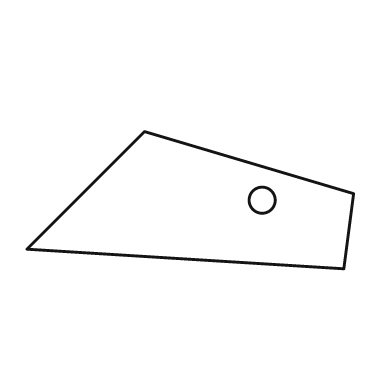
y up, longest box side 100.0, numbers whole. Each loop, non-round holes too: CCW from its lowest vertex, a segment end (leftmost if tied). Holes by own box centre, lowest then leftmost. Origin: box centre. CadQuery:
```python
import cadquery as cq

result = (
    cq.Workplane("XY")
    .moveTo(47.0, -21.0)
    .lineTo(50.0, 2.0)
    .lineTo(-14.0, 21.0)
    .lineTo(-50.0, -15.0)
    .close()
    .moveTo(22.0, 0.0)
    .circle(4.0)
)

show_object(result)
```